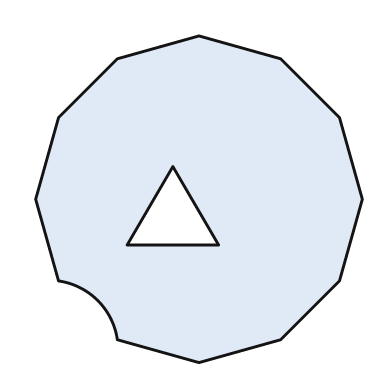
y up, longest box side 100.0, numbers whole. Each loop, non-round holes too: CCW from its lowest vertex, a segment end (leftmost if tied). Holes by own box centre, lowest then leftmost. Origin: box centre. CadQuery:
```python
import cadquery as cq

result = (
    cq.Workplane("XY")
    .moveTo(0.0, -50.0)
    .lineTo(25.0, -43.0)
    .lineTo(43.0, -25.0)
    .lineTo(50.0, 0.0)
    .lineTo(43.0, 25.0)
    .lineTo(25.0, 43.0)
    .lineTo(0.0, 50.0)
    .lineTo(-25.0, 43.0)
    .lineTo(-43.0, 25.0)
    .lineTo(-50.0, 0.0)
    .lineTo(-43.0, -25.0)
    .threePointArc((-31.0, -31.0), (-25.0, -43.0))
    .close()
    .moveTo(-22.0, -14.0)
    .lineTo(6.0, -14.0)
    .lineTo(-8.0, 10.0)
    .close()
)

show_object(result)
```